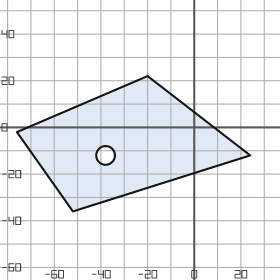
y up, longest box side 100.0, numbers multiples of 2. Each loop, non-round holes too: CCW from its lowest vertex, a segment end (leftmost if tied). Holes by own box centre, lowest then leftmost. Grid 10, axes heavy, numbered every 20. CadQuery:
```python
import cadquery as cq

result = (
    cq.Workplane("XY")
    .moveTo(-52.0, -36.0)
    .lineTo(24.0, -12.0)
    .lineTo(-20.0, 22.0)
    .lineTo(-76.0, -2.0)
    .close()
    .moveTo(-38.0, -12.0)
    .circle(4.0)
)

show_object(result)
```